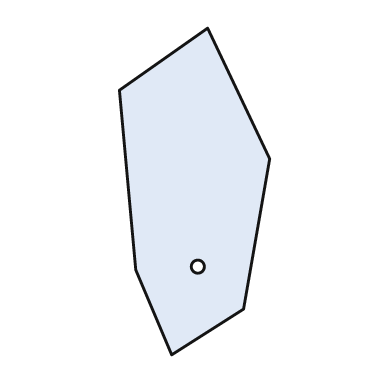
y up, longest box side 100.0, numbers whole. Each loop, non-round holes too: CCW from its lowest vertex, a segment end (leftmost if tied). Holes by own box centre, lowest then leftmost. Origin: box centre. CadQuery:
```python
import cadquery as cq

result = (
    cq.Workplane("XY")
    .moveTo(-7.0, -50.0)
    .lineTo(15.0, -36.0)
    .lineTo(23.0, 10.0)
    .lineTo(4.0, 50.0)
    .lineTo(-23.0, 31.0)
    .lineTo(-18.0, -24.0)
    .close()
    .moveTo(1.0, -23.0)
    .circle(2.0)
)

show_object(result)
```